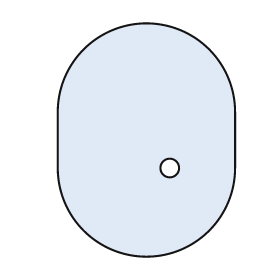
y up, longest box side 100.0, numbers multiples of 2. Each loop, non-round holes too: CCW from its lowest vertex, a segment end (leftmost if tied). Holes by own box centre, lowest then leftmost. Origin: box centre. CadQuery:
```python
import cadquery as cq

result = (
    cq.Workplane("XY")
    .moveTo(-38.0, -12.0)
    .threePointArc((0.0, -50.0), (38.0, -12.0))
    .lineTo(38.0, 12.0)
    .threePointArc((0.0, 50.0), (-38.0, 12.0))
    .close()
    .moveTo(10.0, -12.0)
    .circle(4.0)
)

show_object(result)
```